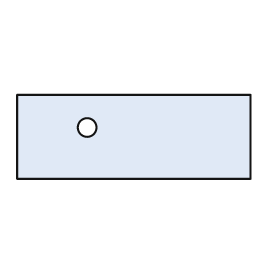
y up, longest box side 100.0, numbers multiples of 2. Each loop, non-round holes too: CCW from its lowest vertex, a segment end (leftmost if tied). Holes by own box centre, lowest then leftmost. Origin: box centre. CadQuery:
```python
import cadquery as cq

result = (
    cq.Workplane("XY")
    .moveTo(-50.0, -18.0)
    .lineTo(50.0, -18.0)
    .lineTo(50.0, 18.0)
    .lineTo(-50.0, 18.0)
    .close()
    .moveTo(-20.0, 4.0)
    .circle(4.0)
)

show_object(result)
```